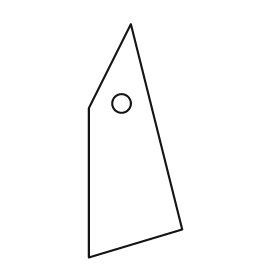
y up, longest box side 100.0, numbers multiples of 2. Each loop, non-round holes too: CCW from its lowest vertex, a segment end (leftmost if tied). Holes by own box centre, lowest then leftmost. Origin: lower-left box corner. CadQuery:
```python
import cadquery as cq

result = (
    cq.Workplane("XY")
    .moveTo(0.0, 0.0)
    .lineTo(40.0, 12.0)
    .lineTo(18.0, 100.0)
    .lineTo(0.0, 64.0)
    .close()
    .moveTo(14.0, 66.0)
    .circle(4.0)
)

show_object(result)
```